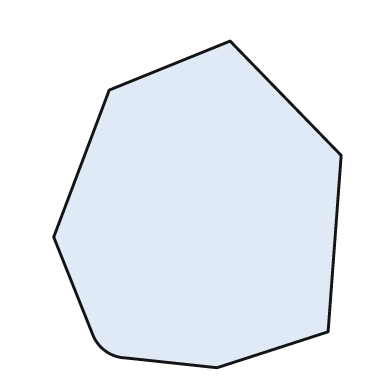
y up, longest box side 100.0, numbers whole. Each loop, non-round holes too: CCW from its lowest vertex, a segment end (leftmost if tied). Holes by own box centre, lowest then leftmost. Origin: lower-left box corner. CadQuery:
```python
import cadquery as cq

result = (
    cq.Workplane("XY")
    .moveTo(50.0, 0.0)
    .lineTo(84.0, 11.0)
    .lineTo(88.0, 65.0)
    .lineTo(54.0, 100.0)
    .lineTo(17.0, 85.0)
    .lineTo(0.0, 40.0)
    .lineTo(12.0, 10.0)
    .threePointArc((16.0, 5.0), (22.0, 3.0))
    .close()
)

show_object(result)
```